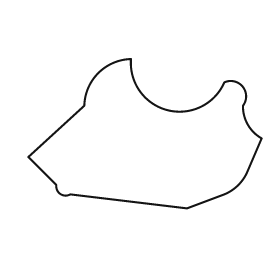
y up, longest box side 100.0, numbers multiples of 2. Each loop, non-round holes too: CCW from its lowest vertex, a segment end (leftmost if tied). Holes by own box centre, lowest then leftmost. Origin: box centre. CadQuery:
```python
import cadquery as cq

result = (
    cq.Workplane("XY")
    .moveTo(18.0, -32.0)
    .lineTo(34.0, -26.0)
    .threePointArc((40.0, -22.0), (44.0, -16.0))
    .lineTo(50.0, -2.0)
    .threePointArc((44.0, 4.0), (42.0, 12.0))
    .threePointArc((42.0, 20.0), (34.0, 22.0))
    .threePointArc((10.0, 10.0), (-6.0, 32.0))
    .threePointArc((-20.0, 26.0), (-26.0, 12.0))
    .lineTo(-50.0, -10.0)
    .lineTo(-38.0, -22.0)
    .threePointArc((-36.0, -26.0), (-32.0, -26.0))
    .close()
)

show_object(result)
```